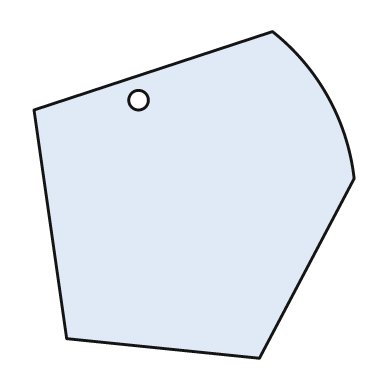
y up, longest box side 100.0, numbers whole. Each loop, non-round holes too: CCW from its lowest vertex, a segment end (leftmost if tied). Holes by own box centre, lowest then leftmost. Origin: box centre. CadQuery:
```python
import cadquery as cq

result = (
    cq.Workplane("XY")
    .moveTo(20.0, -50.0)
    .lineTo(49.0, 5.0)
    .threePointArc((41.0, 30.0), (24.0, 50.0))
    .lineTo(-49.0, 26.0)
    .lineTo(-39.0, -44.0)
    .close()
    .moveTo(-17.0, 29.0)
    .circle(3.0)
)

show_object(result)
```